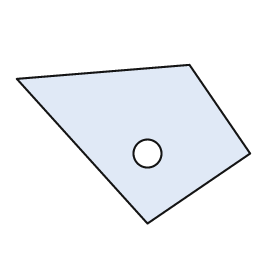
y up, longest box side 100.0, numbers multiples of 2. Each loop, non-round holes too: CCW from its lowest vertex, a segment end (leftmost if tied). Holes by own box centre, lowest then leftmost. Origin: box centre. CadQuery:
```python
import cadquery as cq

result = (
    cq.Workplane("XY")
    .moveTo(6.0, -34.0)
    .lineTo(50.0, -4.0)
    .lineTo(24.0, 34.0)
    .lineTo(-50.0, 28.0)
    .close()
    .moveTo(6.0, -4.0)
    .circle(6.0)
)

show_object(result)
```